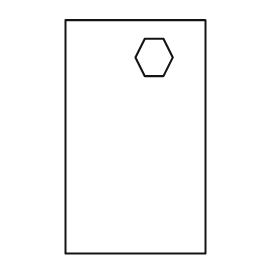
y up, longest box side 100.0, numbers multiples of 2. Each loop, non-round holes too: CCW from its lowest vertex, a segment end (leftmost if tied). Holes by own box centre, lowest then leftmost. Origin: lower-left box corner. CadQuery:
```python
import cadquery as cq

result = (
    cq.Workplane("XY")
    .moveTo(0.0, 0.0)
    .lineTo(60.0, 0.0)
    .lineTo(60.0, 100.0)
    .lineTo(0.0, 100.0)
    .close()
    .moveTo(34.0, 76.0)
    .lineTo(42.0, 76.0)
    .lineTo(46.0, 84.0)
    .lineTo(42.0, 92.0)
    .lineTo(34.0, 92.0)
    .lineTo(30.0, 84.0)
    .close()
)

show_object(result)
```